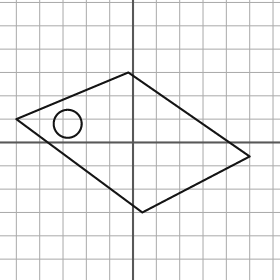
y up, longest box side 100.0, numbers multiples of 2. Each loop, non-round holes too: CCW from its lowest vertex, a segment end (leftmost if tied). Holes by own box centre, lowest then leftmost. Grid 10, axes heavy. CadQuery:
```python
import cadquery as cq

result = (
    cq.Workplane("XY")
    .moveTo(4.0, -30.0)
    .lineTo(50.0, -6.0)
    .lineTo(-2.0, 30.0)
    .lineTo(-50.0, 10.0)
    .close()
    .moveTo(-28.0, 8.0)
    .circle(6.0)
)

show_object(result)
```